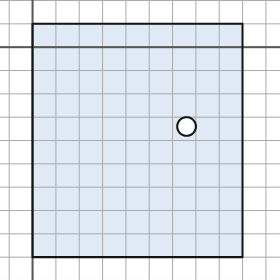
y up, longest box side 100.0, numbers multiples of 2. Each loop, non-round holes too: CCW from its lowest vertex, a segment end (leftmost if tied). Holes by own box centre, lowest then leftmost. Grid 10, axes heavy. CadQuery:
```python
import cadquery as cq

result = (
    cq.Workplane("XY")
    .moveTo(0.0, -90.0)
    .lineTo(90.0, -90.0)
    .lineTo(90.0, 10.0)
    .lineTo(0.0, 10.0)
    .close()
    .moveTo(66.0, -34.0)
    .circle(4.0)
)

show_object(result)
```